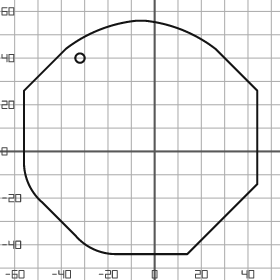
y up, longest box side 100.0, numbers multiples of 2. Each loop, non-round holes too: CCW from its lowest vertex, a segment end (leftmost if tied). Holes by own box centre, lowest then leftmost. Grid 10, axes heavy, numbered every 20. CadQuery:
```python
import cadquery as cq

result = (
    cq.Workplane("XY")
    .moveTo(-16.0, -44.0)
    .lineTo(14.0, -44.0)
    .lineTo(44.0, -14.0)
    .lineTo(44.0, 26.0)
    .lineTo(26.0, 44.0)
    .threePointArc((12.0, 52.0), (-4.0, 56.0))
    .lineTo(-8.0, 56.0)
    .threePointArc((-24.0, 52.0), (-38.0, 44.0))
    .lineTo(-56.0, 26.0)
    .lineTo(-56.0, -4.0)
    .threePointArc((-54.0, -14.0), (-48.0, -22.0))
    .lineTo(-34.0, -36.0)
    .threePointArc((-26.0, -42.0), (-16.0, -44.0))
    .close()
    .moveTo(-32.0, 40.0)
    .circle(2.0)
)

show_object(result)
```